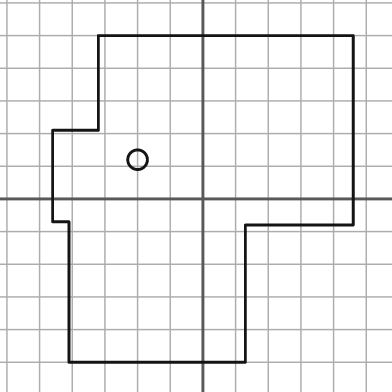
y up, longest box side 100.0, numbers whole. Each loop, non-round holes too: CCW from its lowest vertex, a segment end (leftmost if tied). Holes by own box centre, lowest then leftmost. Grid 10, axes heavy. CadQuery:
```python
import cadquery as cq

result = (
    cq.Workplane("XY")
    .moveTo(-41.0, -50.0)
    .lineTo(13.0, -50.0)
    .lineTo(13.0, -8.0)
    .lineTo(46.0, -8.0)
    .lineTo(46.0, 50.0)
    .lineTo(-32.0, 50.0)
    .lineTo(-32.0, 21.0)
    .lineTo(-46.0, 21.0)
    .lineTo(-46.0, -7.0)
    .lineTo(-41.0, -7.0)
    .close()
    .moveTo(-20.0, 12.0)
    .circle(3.0)
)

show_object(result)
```